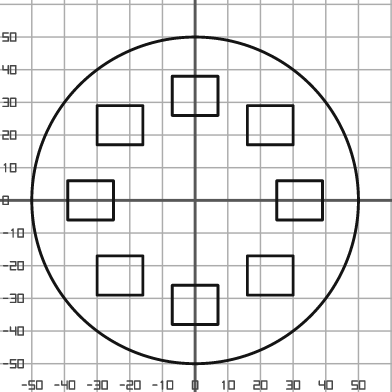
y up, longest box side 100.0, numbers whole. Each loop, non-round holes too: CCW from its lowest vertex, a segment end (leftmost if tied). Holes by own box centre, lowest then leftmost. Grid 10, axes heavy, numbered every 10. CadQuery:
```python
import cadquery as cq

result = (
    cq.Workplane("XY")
    .moveTo(0.0, 0.0)
    .circle(50.0)
    .moveTo(-7.0, -38.0)
    .lineTo(7.0, -38.0)
    .lineTo(7.0, -26.0)
    .lineTo(-7.0, -26.0)
    .close()
    .moveTo(-30.0, -29.0)
    .lineTo(-16.0, -29.0)
    .lineTo(-16.0, -17.0)
    .lineTo(-30.0, -17.0)
    .close()
    .moveTo(16.0, -29.0)
    .lineTo(30.0, -29.0)
    .lineTo(30.0, -17.0)
    .lineTo(16.0, -17.0)
    .close()
    .moveTo(-39.0, -6.0)
    .lineTo(-25.0, -6.0)
    .lineTo(-25.0, 6.0)
    .lineTo(-39.0, 6.0)
    .close()
    .moveTo(25.0, -6.0)
    .lineTo(39.0, -6.0)
    .lineTo(39.0, 6.0)
    .lineTo(25.0, 6.0)
    .close()
    .moveTo(-30.0, 17.0)
    .lineTo(-16.0, 17.0)
    .lineTo(-16.0, 29.0)
    .lineTo(-30.0, 29.0)
    .close()
    .moveTo(16.0, 17.0)
    .lineTo(30.0, 17.0)
    .lineTo(30.0, 29.0)
    .lineTo(16.0, 29.0)
    .close()
    .moveTo(-7.0, 26.0)
    .lineTo(7.0, 26.0)
    .lineTo(7.0, 38.0)
    .lineTo(-7.0, 38.0)
    .close()
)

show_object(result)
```